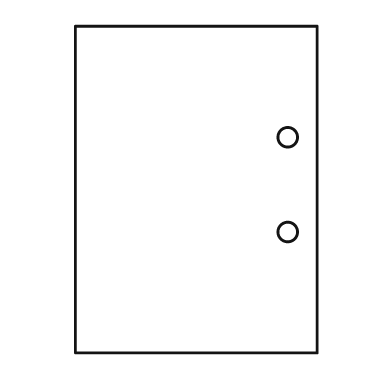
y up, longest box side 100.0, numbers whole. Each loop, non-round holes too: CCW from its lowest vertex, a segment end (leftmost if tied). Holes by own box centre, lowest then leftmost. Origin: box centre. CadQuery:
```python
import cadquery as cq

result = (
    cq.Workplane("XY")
    .moveTo(-37.0, -50.0)
    .lineTo(37.0, -50.0)
    .lineTo(37.0, 50.0)
    .lineTo(-37.0, 50.0)
    .close()
    .moveTo(28.0, -13.0)
    .circle(3.0)
    .moveTo(28.0, 16.0)
    .circle(3.0)
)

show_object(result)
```